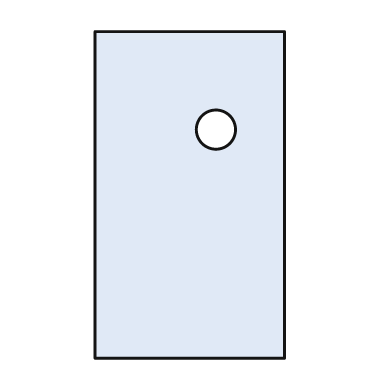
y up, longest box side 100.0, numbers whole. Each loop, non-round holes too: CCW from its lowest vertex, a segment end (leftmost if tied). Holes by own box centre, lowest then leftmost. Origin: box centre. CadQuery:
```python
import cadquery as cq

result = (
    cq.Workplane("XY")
    .moveTo(-29.0, -50.0)
    .lineTo(29.0, -50.0)
    .lineTo(29.0, 50.0)
    .lineTo(-29.0, 50.0)
    .close()
    .moveTo(8.0, 20.0)
    .circle(6.0)
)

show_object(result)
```